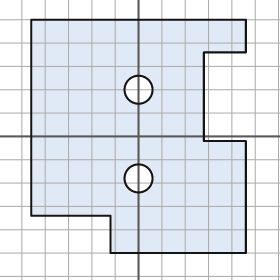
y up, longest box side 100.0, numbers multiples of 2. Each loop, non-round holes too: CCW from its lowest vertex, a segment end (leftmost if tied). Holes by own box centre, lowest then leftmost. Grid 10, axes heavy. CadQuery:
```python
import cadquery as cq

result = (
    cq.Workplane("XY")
    .moveTo(-12.0, -50.0)
    .lineTo(46.0, -50.0)
    .lineTo(46.0, -2.0)
    .lineTo(28.0, -2.0)
    .lineTo(28.0, 36.0)
    .lineTo(46.0, 36.0)
    .lineTo(46.0, 50.0)
    .lineTo(-46.0, 50.0)
    .lineTo(-46.0, -34.0)
    .lineTo(-12.0, -34.0)
    .close()
    .moveTo(0.0, -18.0)
    .circle(6.0)
    .moveTo(0.0, 20.0)
    .circle(6.0)
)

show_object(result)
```